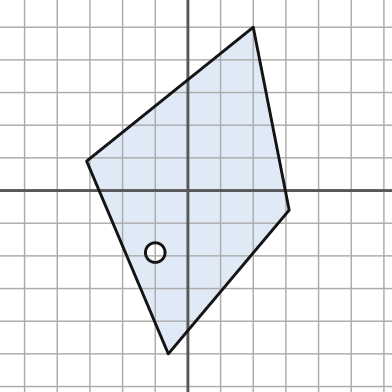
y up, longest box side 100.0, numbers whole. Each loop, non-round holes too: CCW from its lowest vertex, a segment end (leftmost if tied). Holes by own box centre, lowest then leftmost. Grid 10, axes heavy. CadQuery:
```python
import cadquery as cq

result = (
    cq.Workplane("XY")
    .moveTo(-6.0, -50.0)
    .lineTo(31.0, -6.0)
    .lineTo(20.0, 50.0)
    .lineTo(-31.0, 9.0)
    .close()
    .moveTo(-10.0, -19.0)
    .circle(3.0)
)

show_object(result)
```